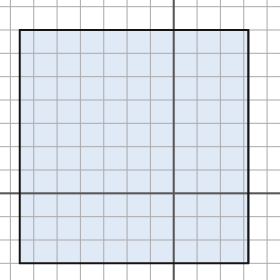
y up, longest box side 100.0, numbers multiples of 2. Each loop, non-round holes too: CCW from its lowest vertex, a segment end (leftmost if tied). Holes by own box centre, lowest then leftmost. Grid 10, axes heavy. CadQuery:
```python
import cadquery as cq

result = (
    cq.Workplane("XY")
    .moveTo(-66.0, -30.0)
    .lineTo(32.0, -30.0)
    .lineTo(32.0, 70.0)
    .lineTo(-66.0, 70.0)
    .close()
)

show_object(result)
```